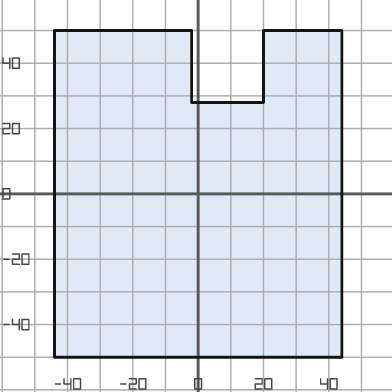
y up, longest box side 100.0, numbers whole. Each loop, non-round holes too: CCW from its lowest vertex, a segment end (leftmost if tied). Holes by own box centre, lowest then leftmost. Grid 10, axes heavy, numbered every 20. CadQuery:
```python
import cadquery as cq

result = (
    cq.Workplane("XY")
    .moveTo(-44.0, -50.0)
    .lineTo(44.0, -50.0)
    .lineTo(44.0, 50.0)
    .lineTo(20.0, 50.0)
    .lineTo(20.0, 28.0)
    .lineTo(-2.0, 28.0)
    .lineTo(-2.0, 50.0)
    .lineTo(-44.0, 50.0)
    .close()
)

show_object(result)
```